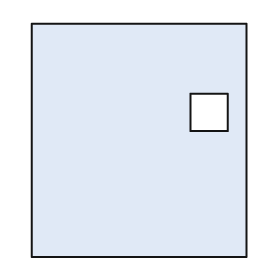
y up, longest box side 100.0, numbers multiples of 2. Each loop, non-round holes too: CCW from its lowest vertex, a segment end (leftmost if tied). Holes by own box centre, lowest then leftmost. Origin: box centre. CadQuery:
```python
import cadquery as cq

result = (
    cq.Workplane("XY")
    .moveTo(-46.0, -50.0)
    .lineTo(46.0, -50.0)
    .lineTo(46.0, 50.0)
    .lineTo(-46.0, 50.0)
    .close()
    .moveTo(22.0, 4.0)
    .lineTo(38.0, 4.0)
    .lineTo(38.0, 20.0)
    .lineTo(22.0, 20.0)
    .close()
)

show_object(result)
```